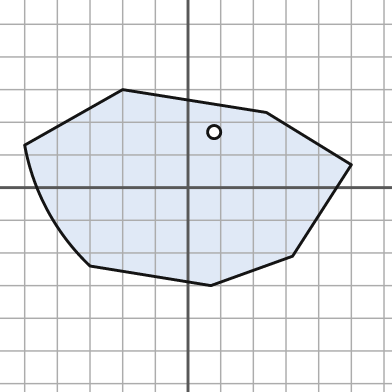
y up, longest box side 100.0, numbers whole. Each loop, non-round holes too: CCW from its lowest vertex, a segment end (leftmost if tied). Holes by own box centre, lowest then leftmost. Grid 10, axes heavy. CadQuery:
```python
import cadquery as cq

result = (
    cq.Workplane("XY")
    .moveTo(7.0, -30.0)
    .lineTo(32.0, -21.0)
    .lineTo(50.0, 7.0)
    .lineTo(24.0, 23.0)
    .lineTo(-20.0, 30.0)
    .lineTo(-50.0, 13.0)
    .threePointArc((-43.0, -7.0), (-30.0, -24.0))
    .close()
    .moveTo(8.0, 17.0)
    .circle(2.0)
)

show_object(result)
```